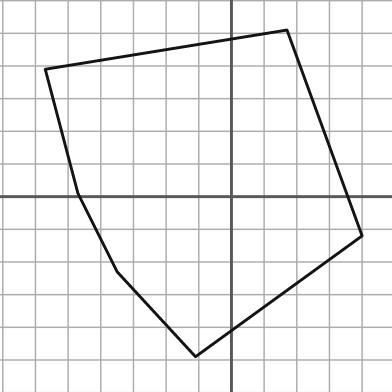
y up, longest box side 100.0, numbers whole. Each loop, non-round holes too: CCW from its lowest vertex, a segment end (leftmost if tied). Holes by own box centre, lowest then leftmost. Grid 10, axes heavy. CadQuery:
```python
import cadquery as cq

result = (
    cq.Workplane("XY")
    .moveTo(-11.0, -49.0)
    .lineTo(40.0, -12.0)
    .lineTo(17.0, 51.0)
    .lineTo(-57.0, 39.0)
    .lineTo(-47.0, 1.0)
    .lineTo(-35.0, -23.0)
    .close()
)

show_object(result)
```